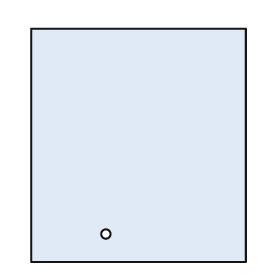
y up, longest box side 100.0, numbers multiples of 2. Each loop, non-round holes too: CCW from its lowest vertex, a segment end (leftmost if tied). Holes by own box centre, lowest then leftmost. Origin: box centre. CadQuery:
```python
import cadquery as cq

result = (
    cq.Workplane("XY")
    .moveTo(-46.0, -50.0)
    .lineTo(46.0, -50.0)
    .lineTo(46.0, 50.0)
    .lineTo(-46.0, 50.0)
    .close()
    .moveTo(-14.0, -38.0)
    .circle(2.0)
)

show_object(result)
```